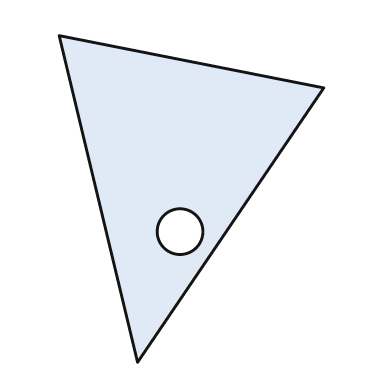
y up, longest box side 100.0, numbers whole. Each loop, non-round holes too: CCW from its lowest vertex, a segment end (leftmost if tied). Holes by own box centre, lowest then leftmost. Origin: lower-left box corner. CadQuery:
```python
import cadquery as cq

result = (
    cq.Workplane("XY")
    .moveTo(24.0, 0.0)
    .lineTo(81.0, 84.0)
    .lineTo(0.0, 100.0)
    .close()
    .moveTo(37.0, 40.0)
    .circle(7.0)
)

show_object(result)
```